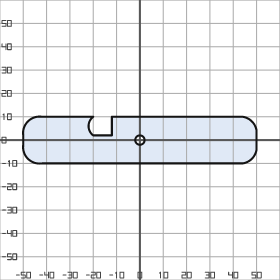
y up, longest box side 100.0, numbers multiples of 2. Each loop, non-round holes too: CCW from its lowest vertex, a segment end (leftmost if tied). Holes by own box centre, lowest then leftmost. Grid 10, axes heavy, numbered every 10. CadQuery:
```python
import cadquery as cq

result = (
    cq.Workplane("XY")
    .moveTo(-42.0, -10.0)
    .lineTo(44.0, -10.0)
    .threePointArc((48.0, -8.0), (50.0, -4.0))
    .lineTo(50.0, 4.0)
    .threePointArc((48.0, 8.0), (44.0, 10.0))
    .lineTo(-12.0, 10.0)
    .lineTo(-12.0, 2.0)
    .lineTo(-20.0, 2.0)
    .threePointArc((-22.0, 6.0), (-20.0, 10.0))
    .lineTo(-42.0, 10.0)
    .threePointArc((-48.0, 8.0), (-50.0, 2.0))
    .lineTo(-50.0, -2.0)
    .threePointArc((-48.0, -8.0), (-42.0, -10.0))
    .close()
    .moveTo(0.0, 0.0)
    .circle(2.0)
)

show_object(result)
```